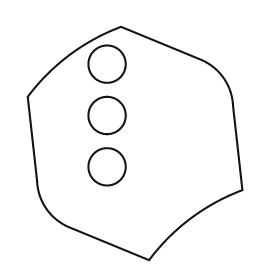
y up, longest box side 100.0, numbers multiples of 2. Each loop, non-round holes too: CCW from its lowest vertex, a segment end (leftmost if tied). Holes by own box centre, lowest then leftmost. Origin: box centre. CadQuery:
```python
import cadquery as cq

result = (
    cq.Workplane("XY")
    .moveTo(6.0, -50.0)
    .threePointArc((24.0, -32.0), (46.0, -20.0))
    .lineTo(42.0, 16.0)
    .threePointArc((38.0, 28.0), (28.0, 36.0))
    .lineTo(-6.0, 50.0)
    .threePointArc((-28.0, 38.0), (-46.0, 20.0))
    .lineTo(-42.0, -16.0)
    .threePointArc((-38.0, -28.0), (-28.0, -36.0))
    .close()
    .moveTo(-12.0, -10.0)
    .circle(8.0)
    .moveTo(-12.0, 12.0)
    .circle(8.0)
    .moveTo(-12.0, 34.0)
    .circle(8.0)
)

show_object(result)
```